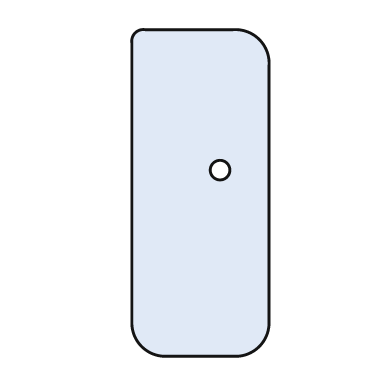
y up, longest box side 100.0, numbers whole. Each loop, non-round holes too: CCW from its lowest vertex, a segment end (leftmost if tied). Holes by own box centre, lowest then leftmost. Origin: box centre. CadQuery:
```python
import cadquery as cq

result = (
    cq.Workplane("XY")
    .moveTo(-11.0, -50.0)
    .lineTo(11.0, -50.0)
    .threePointArc((18.0, -47.0), (21.0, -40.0))
    .lineTo(21.0, 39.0)
    .threePointArc((18.0, 47.0), (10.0, 50.0))
    .lineTo(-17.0, 50.0)
    .threePointArc((-20.0, 49.0), (-21.0, 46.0))
    .lineTo(-21.0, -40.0)
    .threePointArc((-18.0, -47.0), (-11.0, -50.0))
    .close()
    .moveTo(6.0, 7.0)
    .circle(3.0)
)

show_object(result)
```